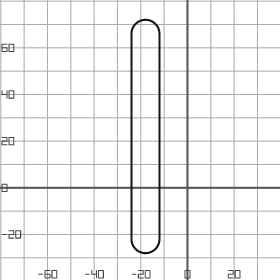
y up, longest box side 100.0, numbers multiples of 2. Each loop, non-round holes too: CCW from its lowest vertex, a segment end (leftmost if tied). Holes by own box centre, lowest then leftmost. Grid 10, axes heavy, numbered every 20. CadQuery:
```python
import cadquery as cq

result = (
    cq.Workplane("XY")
    .moveTo(-24.0, -22.0)
    .threePointArc((-18.0, -28.0), (-12.0, -22.0))
    .lineTo(-12.0, 66.0)
    .threePointArc((-18.0, 72.0), (-24.0, 66.0))
    .close()
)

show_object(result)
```